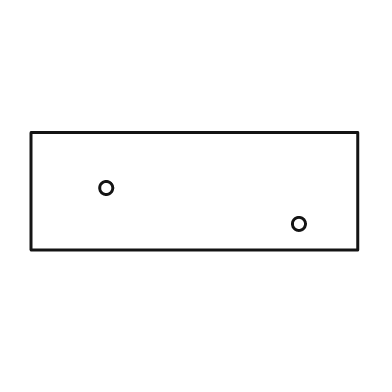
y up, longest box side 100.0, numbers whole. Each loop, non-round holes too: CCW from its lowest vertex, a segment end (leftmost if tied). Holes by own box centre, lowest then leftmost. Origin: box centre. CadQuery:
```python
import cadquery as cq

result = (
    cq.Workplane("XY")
    .moveTo(-50.0, -18.0)
    .lineTo(50.0, -18.0)
    .lineTo(50.0, 18.0)
    .lineTo(-50.0, 18.0)
    .close()
    .moveTo(32.0, -10.0)
    .circle(2.0)
    .moveTo(-27.0, 1.0)
    .circle(2.0)
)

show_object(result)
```